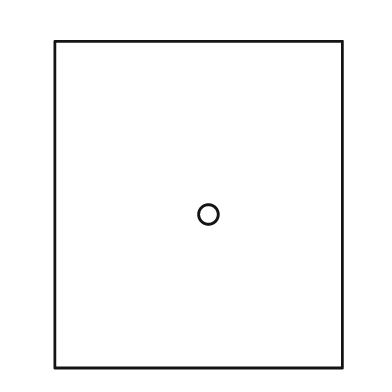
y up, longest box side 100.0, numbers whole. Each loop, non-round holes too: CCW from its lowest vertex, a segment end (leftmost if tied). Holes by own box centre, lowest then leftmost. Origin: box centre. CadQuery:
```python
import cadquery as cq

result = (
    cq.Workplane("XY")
    .moveTo(-44.0, -50.0)
    .lineTo(44.0, -50.0)
    .lineTo(44.0, 50.0)
    .lineTo(-44.0, 50.0)
    .close()
    .moveTo(3.0, -3.0)
    .circle(3.0)
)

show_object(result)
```